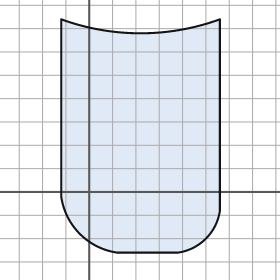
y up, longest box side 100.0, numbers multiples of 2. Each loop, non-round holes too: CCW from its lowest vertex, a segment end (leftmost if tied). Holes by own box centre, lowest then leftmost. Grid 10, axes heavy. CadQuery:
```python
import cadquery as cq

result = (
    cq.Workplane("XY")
    .moveTo(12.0, -26.0)
    .lineTo(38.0, -26.0)
    .threePointArc((50.0, -20.0), (56.0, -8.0))
    .lineTo(56.0, 74.0)
    .threePointArc((22.0, 68.0), (-12.0, 74.0))
    .lineTo(-12.0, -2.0)
    .threePointArc((-4.0, -18.0), (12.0, -26.0))
    .close()
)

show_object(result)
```